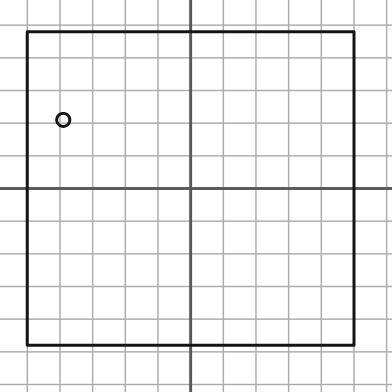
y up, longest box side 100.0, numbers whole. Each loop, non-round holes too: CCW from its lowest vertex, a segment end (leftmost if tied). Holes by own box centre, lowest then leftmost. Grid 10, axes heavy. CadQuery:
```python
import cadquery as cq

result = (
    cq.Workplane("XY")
    .moveTo(-50.0, -48.0)
    .lineTo(50.0, -48.0)
    .lineTo(50.0, 48.0)
    .lineTo(-50.0, 48.0)
    .close()
    .moveTo(-39.0, 21.0)
    .circle(2.0)
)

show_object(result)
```